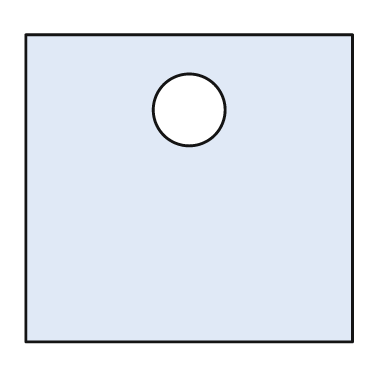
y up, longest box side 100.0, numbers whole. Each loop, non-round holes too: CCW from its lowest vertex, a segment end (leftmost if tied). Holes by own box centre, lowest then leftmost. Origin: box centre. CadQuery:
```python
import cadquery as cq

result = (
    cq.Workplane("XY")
    .moveTo(-50.0, -47.0)
    .lineTo(50.0, -47.0)
    .lineTo(50.0, 47.0)
    .lineTo(-50.0, 47.0)
    .close()
    .moveTo(0.0, 24.0)
    .circle(11.0)
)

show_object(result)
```